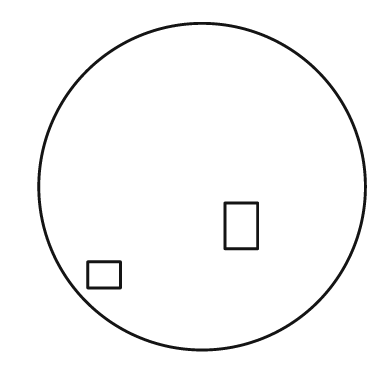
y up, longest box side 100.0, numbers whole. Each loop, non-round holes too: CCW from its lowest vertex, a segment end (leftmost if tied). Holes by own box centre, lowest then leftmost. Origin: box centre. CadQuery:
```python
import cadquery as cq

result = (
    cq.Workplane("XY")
    .moveTo(0.0, 0.0)
    .circle(50.0)
    .moveTo(-35.0, -31.0)
    .lineTo(-25.0, -31.0)
    .lineTo(-25.0, -23.0)
    .lineTo(-35.0, -23.0)
    .close()
    .moveTo(7.0, -19.0)
    .lineTo(17.0, -19.0)
    .lineTo(17.0, -5.0)
    .lineTo(7.0, -5.0)
    .close()
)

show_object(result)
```